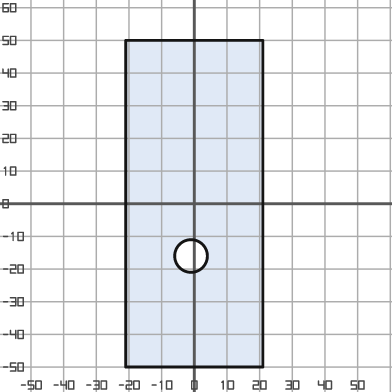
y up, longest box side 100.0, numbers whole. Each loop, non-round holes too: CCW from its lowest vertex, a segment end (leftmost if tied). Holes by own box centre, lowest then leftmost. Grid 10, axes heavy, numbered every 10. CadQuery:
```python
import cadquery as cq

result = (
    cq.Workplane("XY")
    .moveTo(-21.0, -50.0)
    .lineTo(21.0, -50.0)
    .lineTo(21.0, 50.0)
    .lineTo(-21.0, 50.0)
    .close()
    .moveTo(-1.0, -16.0)
    .circle(5.0)
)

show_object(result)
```